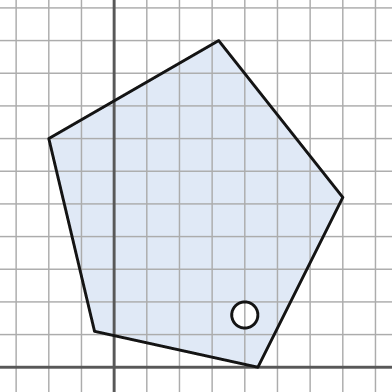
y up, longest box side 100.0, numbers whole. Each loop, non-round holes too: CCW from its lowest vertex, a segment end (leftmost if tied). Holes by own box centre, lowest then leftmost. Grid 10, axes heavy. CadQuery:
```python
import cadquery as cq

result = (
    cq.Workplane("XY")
    .moveTo(44.0, 0.0)
    .lineTo(70.0, 52.0)
    .lineTo(32.0, 100.0)
    .lineTo(-20.0, 70.0)
    .lineTo(-6.0, 11.0)
    .close()
    .moveTo(40.0, 16.0)
    .circle(4.0)
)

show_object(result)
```